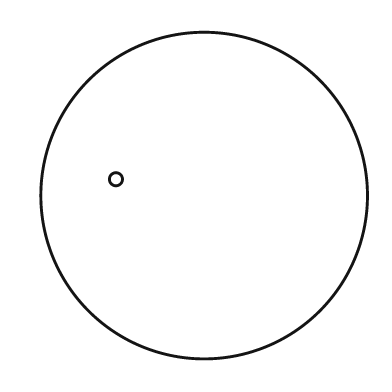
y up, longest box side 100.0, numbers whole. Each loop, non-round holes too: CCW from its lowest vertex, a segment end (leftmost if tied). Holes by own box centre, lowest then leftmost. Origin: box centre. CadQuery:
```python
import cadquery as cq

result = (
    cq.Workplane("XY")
    .moveTo(0.0, 0.0)
    .circle(50.0)
    .moveTo(-27.0, 5.0)
    .circle(2.0)
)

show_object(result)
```